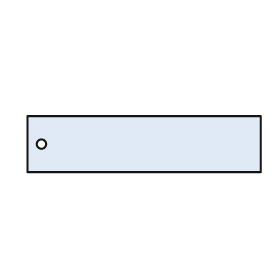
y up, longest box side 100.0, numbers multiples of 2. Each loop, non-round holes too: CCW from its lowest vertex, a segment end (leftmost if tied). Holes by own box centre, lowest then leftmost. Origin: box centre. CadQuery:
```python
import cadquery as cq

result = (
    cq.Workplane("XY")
    .moveTo(-50.0, -12.0)
    .lineTo(50.0, -12.0)
    .lineTo(50.0, 12.0)
    .lineTo(-50.0, 12.0)
    .close()
    .moveTo(-44.0, 0.0)
    .circle(2.0)
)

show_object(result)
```